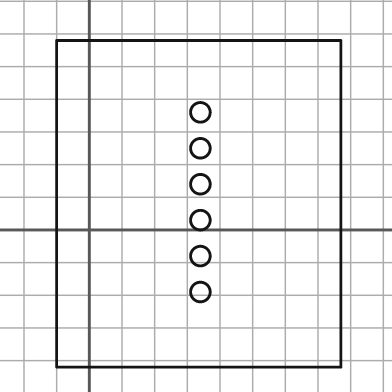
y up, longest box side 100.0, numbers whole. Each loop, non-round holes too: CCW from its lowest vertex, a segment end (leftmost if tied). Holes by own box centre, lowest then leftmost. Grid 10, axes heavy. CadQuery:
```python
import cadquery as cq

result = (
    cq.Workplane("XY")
    .moveTo(-10.0, -42.0)
    .lineTo(77.0, -42.0)
    .lineTo(77.0, 58.0)
    .lineTo(-10.0, 58.0)
    .close()
    .moveTo(34.0, -19.0)
    .circle(3.0)
    .moveTo(34.0, -8.0)
    .circle(3.0)
    .moveTo(34.0, 3.0)
    .circle(3.0)
    .moveTo(34.0, 14.0)
    .circle(3.0)
    .moveTo(34.0, 25.0)
    .circle(3.0)
    .moveTo(34.0, 36.0)
    .circle(3.0)
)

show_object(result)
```